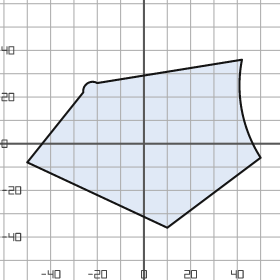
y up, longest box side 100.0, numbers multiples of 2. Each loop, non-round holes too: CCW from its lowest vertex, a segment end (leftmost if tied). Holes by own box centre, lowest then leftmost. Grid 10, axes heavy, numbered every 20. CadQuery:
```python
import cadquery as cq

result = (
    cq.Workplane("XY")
    .moveTo(10.0, -36.0)
    .lineTo(50.0, -6.0)
    .threePointArc((42.0, 14.0), (42.0, 36.0))
    .lineTo(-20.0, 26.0)
    .threePointArc((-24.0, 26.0), (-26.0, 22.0))
    .lineTo(-50.0, -8.0)
    .close()
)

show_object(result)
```